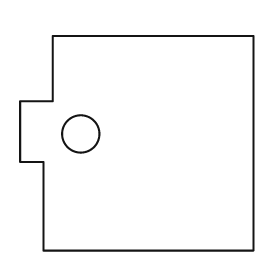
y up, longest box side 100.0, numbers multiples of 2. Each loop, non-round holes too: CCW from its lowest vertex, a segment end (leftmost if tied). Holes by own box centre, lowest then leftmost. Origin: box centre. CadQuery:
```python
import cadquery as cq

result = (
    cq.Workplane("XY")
    .moveTo(-40.0, -46.0)
    .lineTo(50.0, -46.0)
    .lineTo(50.0, 46.0)
    .lineTo(-36.0, 46.0)
    .lineTo(-36.0, 18.0)
    .lineTo(-50.0, 18.0)
    .lineTo(-50.0, -8.0)
    .lineTo(-40.0, -8.0)
    .close()
    .moveTo(-24.0, 4.0)
    .circle(8.0)
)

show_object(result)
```